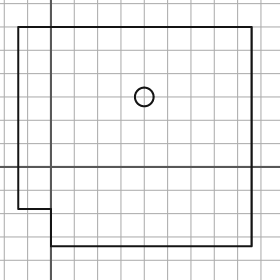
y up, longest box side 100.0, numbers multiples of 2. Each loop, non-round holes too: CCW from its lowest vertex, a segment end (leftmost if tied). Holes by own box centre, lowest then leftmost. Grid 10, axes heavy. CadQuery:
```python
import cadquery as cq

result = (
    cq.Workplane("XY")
    .moveTo(0.0, -34.0)
    .lineTo(86.0, -34.0)
    .lineTo(86.0, 60.0)
    .lineTo(-14.0, 60.0)
    .lineTo(-14.0, -18.0)
    .lineTo(0.0, -18.0)
    .close()
    .moveTo(40.0, 30.0)
    .circle(4.0)
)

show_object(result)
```